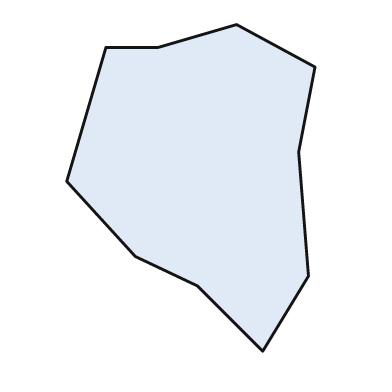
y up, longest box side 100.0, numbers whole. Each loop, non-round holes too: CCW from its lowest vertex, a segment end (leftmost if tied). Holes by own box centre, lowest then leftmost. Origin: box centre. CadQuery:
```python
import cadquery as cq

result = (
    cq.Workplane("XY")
    .moveTo(22.0, -50.0)
    .lineTo(36.0, -27.0)
    .lineTo(33.0, 11.0)
    .lineTo(38.0, 37.0)
    .lineTo(14.0, 50.0)
    .lineTo(-10.0, 43.0)
    .lineTo(-26.0, 43.0)
    .lineTo(-38.0, 2.0)
    .lineTo(-17.0, -21.0)
    .lineTo(2.0, -30.0)
    .close()
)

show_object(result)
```